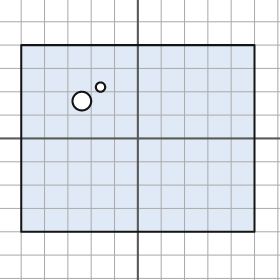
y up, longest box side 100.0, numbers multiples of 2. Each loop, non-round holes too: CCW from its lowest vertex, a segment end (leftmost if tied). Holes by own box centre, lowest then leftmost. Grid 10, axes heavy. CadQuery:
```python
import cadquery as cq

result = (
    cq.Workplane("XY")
    .moveTo(-50.0, -40.0)
    .lineTo(50.0, -40.0)
    .lineTo(50.0, 40.0)
    .lineTo(-50.0, 40.0)
    .close()
    .moveTo(-24.0, 16.0)
    .circle(4.0)
    .moveTo(-16.0, 22.0)
    .circle(2.0)
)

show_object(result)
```